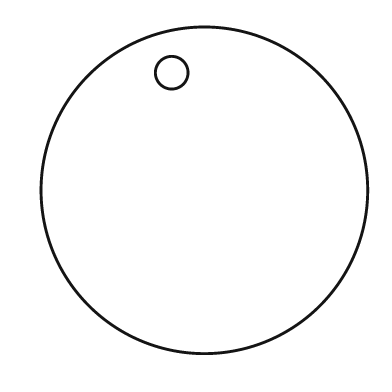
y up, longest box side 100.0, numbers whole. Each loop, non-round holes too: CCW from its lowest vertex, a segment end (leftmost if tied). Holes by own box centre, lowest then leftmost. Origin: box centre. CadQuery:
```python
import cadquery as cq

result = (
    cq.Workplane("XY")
    .moveTo(0.0, 0.0)
    .circle(50.0)
    .moveTo(-10.0, 36.0)
    .circle(5.0)
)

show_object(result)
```